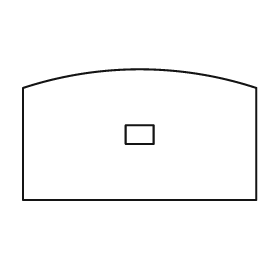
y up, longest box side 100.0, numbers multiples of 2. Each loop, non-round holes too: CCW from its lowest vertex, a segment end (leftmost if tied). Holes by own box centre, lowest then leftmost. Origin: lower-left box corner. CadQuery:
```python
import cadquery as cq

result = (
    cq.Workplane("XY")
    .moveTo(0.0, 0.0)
    .lineTo(100.0, 0.0)
    .lineTo(100.0, 48.0)
    .threePointArc((50.0, 56.0), (0.0, 48.0))
    .close()
    .moveTo(44.0, 24.0)
    .lineTo(56.0, 24.0)
    .lineTo(56.0, 32.0)
    .lineTo(44.0, 32.0)
    .close()
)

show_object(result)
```